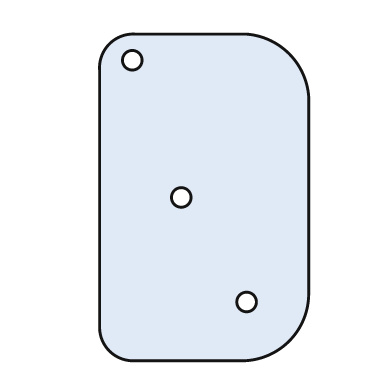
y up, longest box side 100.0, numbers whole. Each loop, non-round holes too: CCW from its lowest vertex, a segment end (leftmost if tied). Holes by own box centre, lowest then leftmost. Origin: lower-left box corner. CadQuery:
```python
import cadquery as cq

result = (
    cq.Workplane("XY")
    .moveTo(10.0, 0.0)
    .lineTo(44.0, 0.0)
    .threePointArc((58.0, 6.0), (64.0, 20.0))
    .lineTo(64.0, 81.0)
    .threePointArc((58.0, 94.0), (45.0, 100.0))
    .lineTo(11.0, 100.0)
    .threePointArc((3.0, 97.0), (0.0, 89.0))
    .lineTo(0.0, 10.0)
    .threePointArc((3.0, 3.0), (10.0, 0.0))
    .close()
    .moveTo(45.0, 18.0)
    .circle(3.0)
    .moveTo(25.0, 50.0)
    .circle(3.0)
    .moveTo(10.0, 92.0)
    .circle(3.0)
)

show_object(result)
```